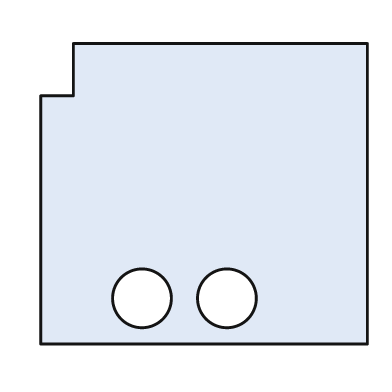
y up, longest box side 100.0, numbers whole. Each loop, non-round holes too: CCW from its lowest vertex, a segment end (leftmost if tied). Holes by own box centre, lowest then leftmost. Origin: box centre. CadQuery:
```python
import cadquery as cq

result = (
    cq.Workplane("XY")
    .moveTo(-50.0, -46.0)
    .lineTo(50.0, -46.0)
    .lineTo(50.0, 46.0)
    .lineTo(-40.0, 46.0)
    .lineTo(-40.0, 30.0)
    .lineTo(-50.0, 30.0)
    .close()
    .moveTo(-19.0, -32.0)
    .circle(9.0)
    .moveTo(7.0, -32.0)
    .circle(9.0)
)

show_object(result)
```